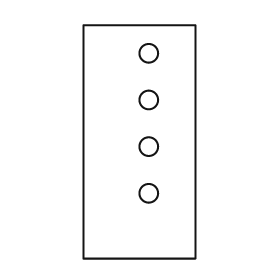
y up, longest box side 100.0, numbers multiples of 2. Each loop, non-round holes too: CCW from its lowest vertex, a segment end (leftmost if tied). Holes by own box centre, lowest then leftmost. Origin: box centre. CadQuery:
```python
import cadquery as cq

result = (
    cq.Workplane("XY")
    .moveTo(-24.0, -50.0)
    .lineTo(24.0, -50.0)
    .lineTo(24.0, 50.0)
    .lineTo(-24.0, 50.0)
    .close()
    .moveTo(4.0, -22.0)
    .circle(4.0)
    .moveTo(4.0, -2.0)
    .circle(4.0)
    .moveTo(4.0, 18.0)
    .circle(4.0)
    .moveTo(4.0, 38.0)
    .circle(4.0)
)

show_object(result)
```